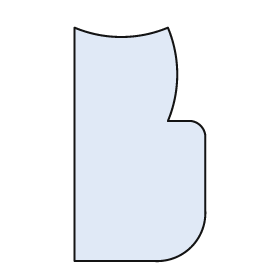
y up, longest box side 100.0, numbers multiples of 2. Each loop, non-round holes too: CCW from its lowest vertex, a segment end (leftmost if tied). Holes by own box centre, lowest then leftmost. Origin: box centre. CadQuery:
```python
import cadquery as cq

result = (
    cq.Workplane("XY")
    .moveTo(-28.0, -50.0)
    .lineTo(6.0, -50.0)
    .threePointArc((22.0, -44.0), (28.0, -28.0))
    .lineTo(28.0, 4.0)
    .threePointArc((26.0, 8.0), (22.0, 10.0))
    .lineTo(12.0, 10.0)
    .threePointArc((16.0, 30.0), (12.0, 50.0))
    .threePointArc((-8.0, 46.0), (-28.0, 50.0))
    .close()
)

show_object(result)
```